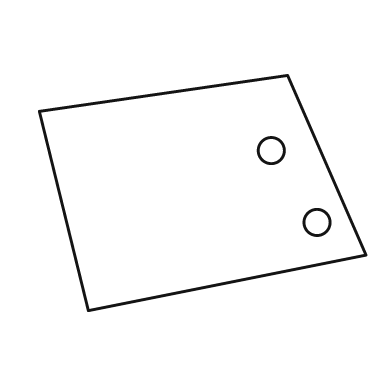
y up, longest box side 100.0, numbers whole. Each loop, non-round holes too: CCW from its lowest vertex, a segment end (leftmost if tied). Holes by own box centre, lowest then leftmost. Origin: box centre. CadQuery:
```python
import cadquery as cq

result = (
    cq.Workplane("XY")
    .moveTo(-35.0, -36.0)
    .lineTo(50.0, -19.0)
    .lineTo(26.0, 36.0)
    .lineTo(-50.0, 25.0)
    .close()
    .moveTo(35.0, -9.0)
    .circle(4.0)
    .moveTo(21.0, 13.0)
    .circle(4.0)
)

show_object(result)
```